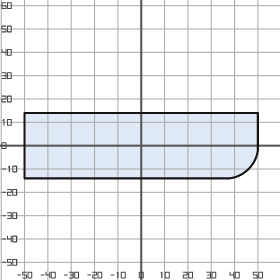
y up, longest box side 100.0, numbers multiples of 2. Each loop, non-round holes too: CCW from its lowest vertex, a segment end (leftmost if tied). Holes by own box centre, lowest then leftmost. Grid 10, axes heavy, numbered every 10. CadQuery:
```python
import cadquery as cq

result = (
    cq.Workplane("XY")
    .moveTo(-50.0, -14.0)
    .lineTo(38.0, -14.0)
    .threePointArc((46.0, -10.0), (50.0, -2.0))
    .lineTo(50.0, 14.0)
    .lineTo(-50.0, 14.0)
    .close()
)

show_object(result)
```